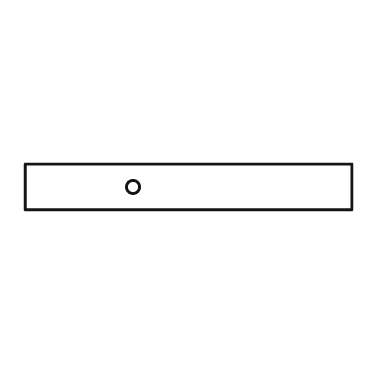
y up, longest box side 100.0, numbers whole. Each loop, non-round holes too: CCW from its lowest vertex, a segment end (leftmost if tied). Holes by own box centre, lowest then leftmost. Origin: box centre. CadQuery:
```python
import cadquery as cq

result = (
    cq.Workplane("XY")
    .moveTo(-50.0, -7.0)
    .lineTo(50.0, -7.0)
    .lineTo(50.0, 7.0)
    .lineTo(-50.0, 7.0)
    .close()
    .moveTo(-17.0, 0.0)
    .circle(2.0)
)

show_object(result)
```